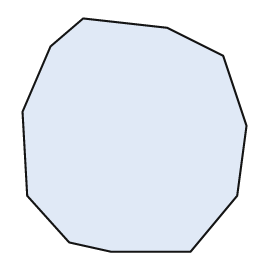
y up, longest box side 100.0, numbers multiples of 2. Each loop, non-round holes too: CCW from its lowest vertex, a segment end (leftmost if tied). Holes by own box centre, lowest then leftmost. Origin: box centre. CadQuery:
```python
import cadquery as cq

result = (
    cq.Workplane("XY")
    .moveTo(-10.0, -50.0)
    .lineTo(24.0, -50.0)
    .lineTo(44.0, -26.0)
    .lineTo(48.0, 4.0)
    .lineTo(38.0, 34.0)
    .lineTo(14.0, 46.0)
    .lineTo(-22.0, 50.0)
    .lineTo(-36.0, 38.0)
    .lineTo(-48.0, 10.0)
    .lineTo(-46.0, -26.0)
    .lineTo(-28.0, -46.0)
    .close()
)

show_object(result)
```